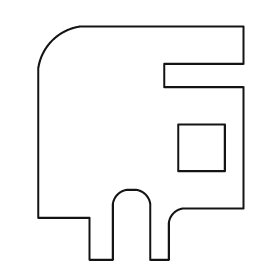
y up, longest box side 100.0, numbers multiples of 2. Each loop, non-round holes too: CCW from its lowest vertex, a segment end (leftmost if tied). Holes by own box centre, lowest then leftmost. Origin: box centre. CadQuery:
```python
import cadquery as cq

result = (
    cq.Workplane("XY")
    .moveTo(-22.0, -50.0)
    .lineTo(-12.0, -50.0)
    .lineTo(-12.0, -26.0)
    .threePointArc((-10.0, -22.0), (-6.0, -20.0))
    .lineTo(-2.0, -20.0)
    .threePointArc((2.0, -22.0), (4.0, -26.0))
    .lineTo(4.0, -50.0)
    .lineTo(12.0, -50.0)
    .lineTo(12.0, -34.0)
    .threePointArc((14.0, -30.0), (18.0, -28.0))
    .lineTo(44.0, -28.0)
    .lineTo(44.0, 24.0)
    .lineTo(10.0, 24.0)
    .lineTo(10.0, 34.0)
    .lineTo(44.0, 34.0)
    .lineTo(44.0, 50.0)
    .lineTo(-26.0, 50.0)
    .threePointArc((-38.0, 44.0), (-44.0, 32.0))
    .lineTo(-44.0, -32.0)
    .lineTo(-22.0, -32.0)
    .close()
    .moveTo(16.0, -12.0)
    .lineTo(36.0, -12.0)
    .lineTo(36.0, 8.0)
    .lineTo(16.0, 8.0)
    .close()
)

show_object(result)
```